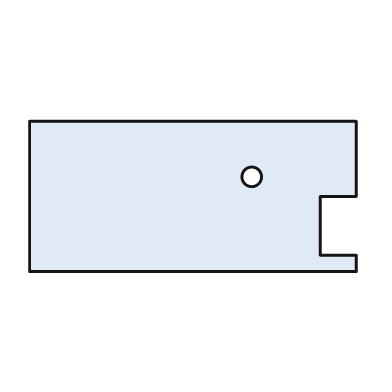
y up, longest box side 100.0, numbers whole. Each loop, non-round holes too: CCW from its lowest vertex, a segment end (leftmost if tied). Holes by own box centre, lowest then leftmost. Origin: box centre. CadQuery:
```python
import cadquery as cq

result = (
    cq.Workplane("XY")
    .moveTo(-50.0, -23.0)
    .lineTo(50.0, -23.0)
    .lineTo(50.0, -18.0)
    .lineTo(39.0, -18.0)
    .lineTo(39.0, 0.0)
    .lineTo(50.0, 0.0)
    .lineTo(50.0, 23.0)
    .lineTo(-50.0, 23.0)
    .close()
    .moveTo(18.0, 6.0)
    .circle(3.0)
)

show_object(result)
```